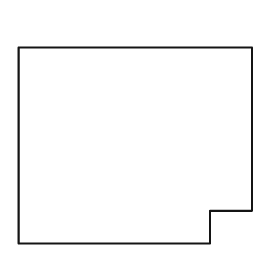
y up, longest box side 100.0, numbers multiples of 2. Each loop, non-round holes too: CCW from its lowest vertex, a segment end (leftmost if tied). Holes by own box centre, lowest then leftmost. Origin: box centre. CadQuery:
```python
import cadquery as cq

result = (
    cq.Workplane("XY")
    .moveTo(-50.0, -42.0)
    .lineTo(32.0, -42.0)
    .lineTo(32.0, -28.0)
    .lineTo(50.0, -28.0)
    .lineTo(50.0, 42.0)
    .lineTo(-50.0, 42.0)
    .close()
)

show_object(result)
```